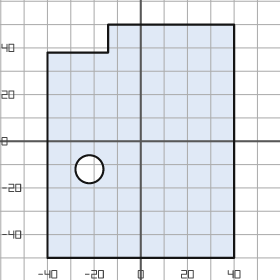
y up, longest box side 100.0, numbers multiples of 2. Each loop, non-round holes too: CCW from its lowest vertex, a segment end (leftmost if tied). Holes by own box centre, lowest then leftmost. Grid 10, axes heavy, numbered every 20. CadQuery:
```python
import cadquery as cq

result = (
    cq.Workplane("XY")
    .moveTo(-40.0, -50.0)
    .lineTo(40.0, -50.0)
    .lineTo(40.0, 50.0)
    .lineTo(-14.0, 50.0)
    .lineTo(-14.0, 38.0)
    .lineTo(-40.0, 38.0)
    .close()
    .moveTo(-22.0, -12.0)
    .circle(6.0)
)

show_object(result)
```